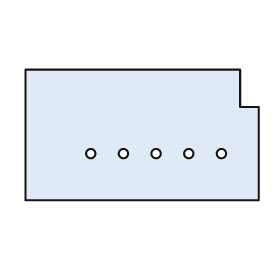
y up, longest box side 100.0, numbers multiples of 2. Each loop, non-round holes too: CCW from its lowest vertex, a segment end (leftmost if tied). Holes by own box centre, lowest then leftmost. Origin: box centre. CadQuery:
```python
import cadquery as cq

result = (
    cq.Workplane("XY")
    .moveTo(-50.0, -28.0)
    .lineTo(50.0, -28.0)
    .lineTo(50.0, 12.0)
    .lineTo(42.0, 12.0)
    .lineTo(42.0, 28.0)
    .lineTo(-50.0, 28.0)
    .close()
    .moveTo(-22.0, -8.0)
    .circle(2.0)
    .moveTo(-8.0, -8.0)
    .circle(2.0)
    .moveTo(6.0, -8.0)
    .circle(2.0)
    .moveTo(20.0, -8.0)
    .circle(2.0)
    .moveTo(34.0, -8.0)
    .circle(2.0)
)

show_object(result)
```